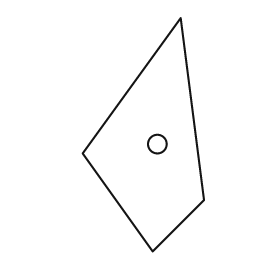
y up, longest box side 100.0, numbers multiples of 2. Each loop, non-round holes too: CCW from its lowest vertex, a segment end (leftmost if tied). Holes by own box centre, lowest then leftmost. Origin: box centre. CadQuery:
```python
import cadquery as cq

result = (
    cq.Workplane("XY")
    .moveTo(4.0, -50.0)
    .lineTo(26.0, -28.0)
    .lineTo(16.0, 50.0)
    .lineTo(-26.0, -8.0)
    .close()
    .moveTo(6.0, -4.0)
    .circle(4.0)
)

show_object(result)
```